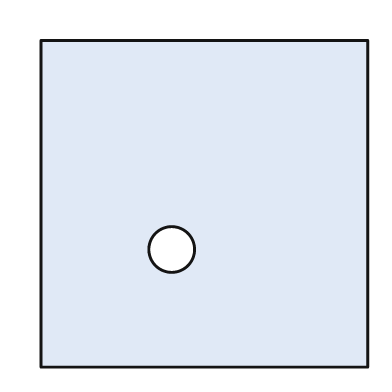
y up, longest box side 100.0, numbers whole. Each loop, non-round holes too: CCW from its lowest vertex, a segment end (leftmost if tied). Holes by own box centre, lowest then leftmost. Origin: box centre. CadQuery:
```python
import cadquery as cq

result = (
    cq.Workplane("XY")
    .moveTo(-50.0, -50.0)
    .lineTo(50.0, -50.0)
    .lineTo(50.0, 50.0)
    .lineTo(-50.0, 50.0)
    .close()
    .moveTo(-10.0, -14.0)
    .circle(7.0)
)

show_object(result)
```